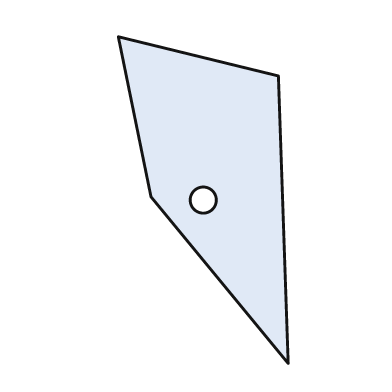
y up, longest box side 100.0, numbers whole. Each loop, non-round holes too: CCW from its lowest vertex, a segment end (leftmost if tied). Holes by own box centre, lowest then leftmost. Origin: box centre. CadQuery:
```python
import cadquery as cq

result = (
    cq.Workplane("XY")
    .moveTo(26.0, -50.0)
    .lineTo(23.0, 38.0)
    .lineTo(-26.0, 50.0)
    .lineTo(-16.0, 1.0)
    .close()
    .moveTo(0.0, 0.0)
    .circle(4.0)
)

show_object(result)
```